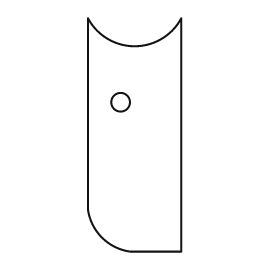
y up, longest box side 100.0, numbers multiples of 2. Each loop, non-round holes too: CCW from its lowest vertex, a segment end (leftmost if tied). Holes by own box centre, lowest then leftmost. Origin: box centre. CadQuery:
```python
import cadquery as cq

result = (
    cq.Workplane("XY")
    .moveTo(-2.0, -50.0)
    .lineTo(20.0, -50.0)
    .lineTo(20.0, 50.0)
    .threePointArc((0.0, 38.0), (-20.0, 50.0))
    .lineTo(-20.0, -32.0)
    .threePointArc((-14.0, -44.0), (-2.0, -50.0))
    .close()
    .moveTo(-6.0, 14.0)
    .circle(4.0)
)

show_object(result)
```